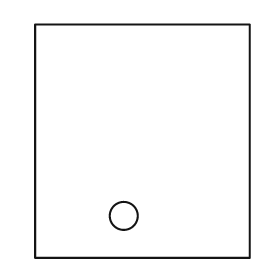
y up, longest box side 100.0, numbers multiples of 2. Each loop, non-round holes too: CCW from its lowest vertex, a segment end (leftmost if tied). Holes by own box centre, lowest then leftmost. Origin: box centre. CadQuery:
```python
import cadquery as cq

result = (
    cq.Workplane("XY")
    .moveTo(-46.0, -50.0)
    .lineTo(46.0, -50.0)
    .lineTo(46.0, 50.0)
    .lineTo(-46.0, 50.0)
    .close()
    .moveTo(-8.0, -32.0)
    .circle(6.0)
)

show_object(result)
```